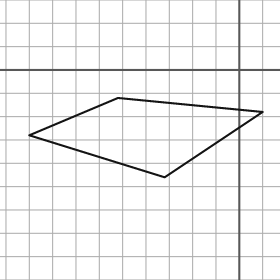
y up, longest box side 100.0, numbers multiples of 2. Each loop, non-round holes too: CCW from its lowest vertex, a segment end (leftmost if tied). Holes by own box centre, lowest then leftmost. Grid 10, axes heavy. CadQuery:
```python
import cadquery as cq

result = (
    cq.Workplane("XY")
    .moveTo(-32.0, -46.0)
    .lineTo(10.0, -18.0)
    .lineTo(-52.0, -12.0)
    .lineTo(-90.0, -28.0)
    .close()
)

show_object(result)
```